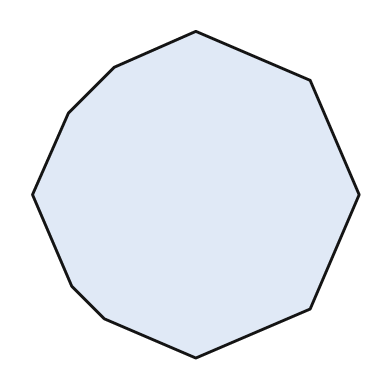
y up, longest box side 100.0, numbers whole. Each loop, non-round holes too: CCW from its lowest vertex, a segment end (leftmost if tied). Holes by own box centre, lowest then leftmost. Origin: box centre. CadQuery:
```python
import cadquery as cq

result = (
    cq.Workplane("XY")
    .moveTo(0.0, -50.0)
    .lineTo(35.0, -35.0)
    .lineTo(50.0, 0.0)
    .lineTo(35.0, 35.0)
    .lineTo(0.0, 50.0)
    .lineTo(-25.0, 39.0)
    .lineTo(-39.0, 25.0)
    .lineTo(-50.0, 0.0)
    .lineTo(-38.0, -28.0)
    .lineTo(-28.0, -38.0)
    .close()
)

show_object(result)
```